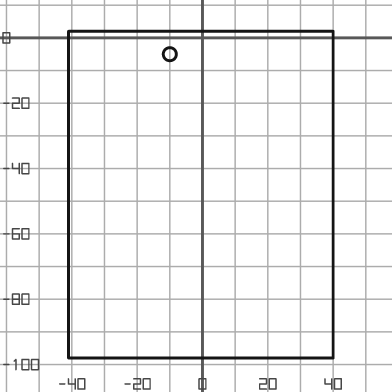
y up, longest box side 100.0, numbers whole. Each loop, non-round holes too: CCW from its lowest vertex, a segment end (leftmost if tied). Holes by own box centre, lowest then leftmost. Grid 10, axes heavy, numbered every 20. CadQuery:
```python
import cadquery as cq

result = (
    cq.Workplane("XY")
    .moveTo(-41.0, -98.0)
    .lineTo(40.0, -98.0)
    .lineTo(40.0, 2.0)
    .lineTo(-41.0, 2.0)
    .close()
    .moveTo(-10.0, -5.0)
    .circle(2.0)
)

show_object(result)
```